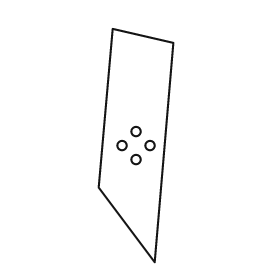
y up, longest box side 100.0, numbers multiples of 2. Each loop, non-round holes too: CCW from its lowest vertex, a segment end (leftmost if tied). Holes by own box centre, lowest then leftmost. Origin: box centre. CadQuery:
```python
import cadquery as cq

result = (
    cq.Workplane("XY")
    .moveTo(8.0, -50.0)
    .lineTo(16.0, 44.0)
    .lineTo(-10.0, 50.0)
    .lineTo(-16.0, -18.0)
    .close()
    .moveTo(0.0, -6.0)
    .circle(2.0)
    .moveTo(-6.0, 0.0)
    .circle(2.0)
    .moveTo(6.0, 0.0)
    .circle(2.0)
    .moveTo(0.0, 6.0)
    .circle(2.0)
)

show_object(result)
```